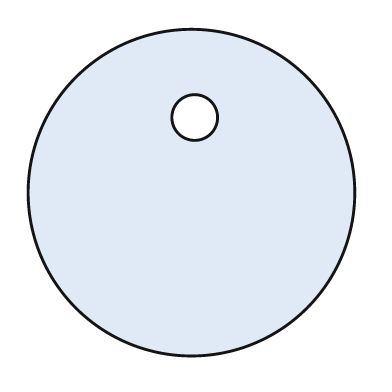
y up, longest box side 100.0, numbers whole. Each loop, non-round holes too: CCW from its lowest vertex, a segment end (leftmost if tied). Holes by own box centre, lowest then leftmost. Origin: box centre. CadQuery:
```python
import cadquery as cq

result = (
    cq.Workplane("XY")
    .moveTo(0.0, 0.0)
    .circle(50.0)
    .moveTo(1.0, 23.0)
    .circle(7.0)
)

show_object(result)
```